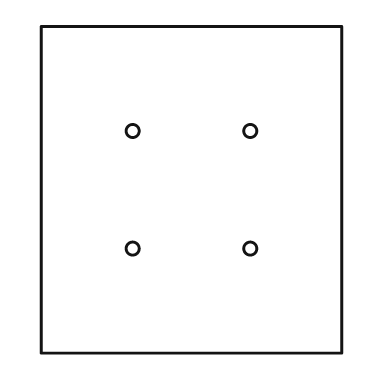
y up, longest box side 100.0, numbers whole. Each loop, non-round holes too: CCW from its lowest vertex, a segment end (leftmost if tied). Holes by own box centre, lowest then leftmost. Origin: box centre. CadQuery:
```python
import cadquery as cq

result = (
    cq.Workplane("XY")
    .moveTo(-46.0, -50.0)
    .lineTo(46.0, -50.0)
    .lineTo(46.0, 50.0)
    .lineTo(-46.0, 50.0)
    .close()
    .moveTo(-18.0, -18.0)
    .circle(2.0)
    .moveTo(18.0, -18.0)
    .circle(2.0)
    .moveTo(-18.0, 18.0)
    .circle(2.0)
    .moveTo(18.0, 18.0)
    .circle(2.0)
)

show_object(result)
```